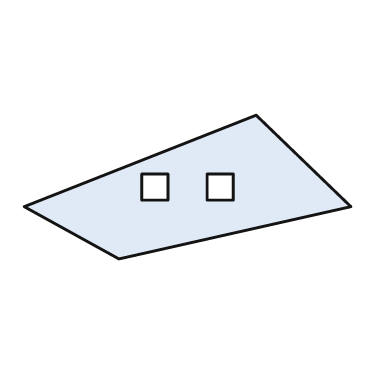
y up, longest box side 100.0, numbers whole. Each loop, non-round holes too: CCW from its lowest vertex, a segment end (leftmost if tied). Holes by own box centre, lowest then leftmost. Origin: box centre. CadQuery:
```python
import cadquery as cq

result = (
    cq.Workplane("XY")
    .moveTo(-21.0, -22.0)
    .lineTo(50.0, -6.0)
    .lineTo(21.0, 22.0)
    .lineTo(-50.0, -6.0)
    .close()
    .moveTo(-14.0, -4.0)
    .lineTo(-6.0, -4.0)
    .lineTo(-6.0, 4.0)
    .lineTo(-14.0, 4.0)
    .close()
    .moveTo(6.0, -4.0)
    .lineTo(14.0, -4.0)
    .lineTo(14.0, 4.0)
    .lineTo(6.0, 4.0)
    .close()
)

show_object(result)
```